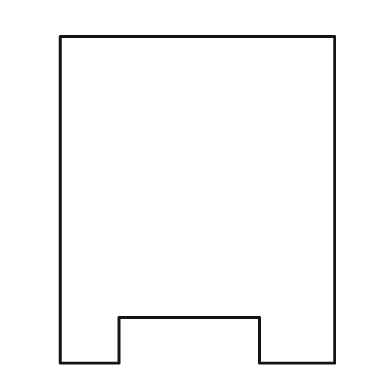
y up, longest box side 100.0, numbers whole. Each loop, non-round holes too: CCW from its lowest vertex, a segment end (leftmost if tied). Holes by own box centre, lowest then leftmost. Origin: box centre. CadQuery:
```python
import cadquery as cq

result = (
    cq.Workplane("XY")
    .moveTo(-42.0, -50.0)
    .lineTo(-24.0, -50.0)
    .lineTo(-24.0, -36.0)
    .lineTo(19.0, -36.0)
    .lineTo(19.0, -50.0)
    .lineTo(42.0, -50.0)
    .lineTo(42.0, 50.0)
    .lineTo(-42.0, 50.0)
    .close()
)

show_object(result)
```